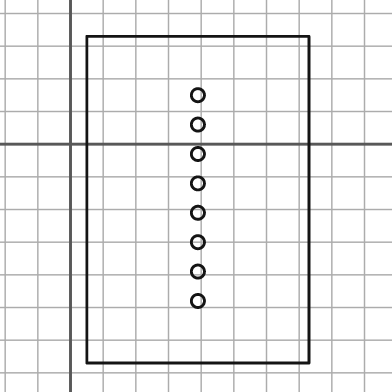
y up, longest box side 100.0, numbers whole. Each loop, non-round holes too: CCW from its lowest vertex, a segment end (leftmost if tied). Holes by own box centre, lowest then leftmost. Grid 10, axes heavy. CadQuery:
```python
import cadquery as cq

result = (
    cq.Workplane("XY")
    .moveTo(5.0, -67.0)
    .lineTo(73.0, -67.0)
    .lineTo(73.0, 33.0)
    .lineTo(5.0, 33.0)
    .close()
    .moveTo(39.0, -48.0)
    .circle(2.0)
    .moveTo(39.0, -39.0)
    .circle(2.0)
    .moveTo(39.0, -30.0)
    .circle(2.0)
    .moveTo(39.0, -21.0)
    .circle(2.0)
    .moveTo(39.0, -12.0)
    .circle(2.0)
    .moveTo(39.0, -3.0)
    .circle(2.0)
    .moveTo(39.0, 6.0)
    .circle(2.0)
    .moveTo(39.0, 15.0)
    .circle(2.0)
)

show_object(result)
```